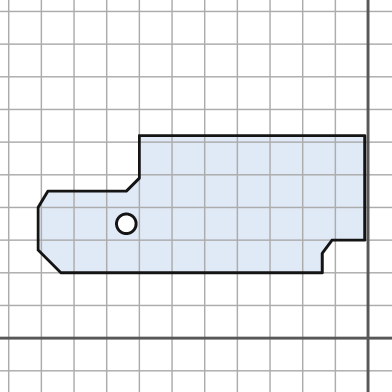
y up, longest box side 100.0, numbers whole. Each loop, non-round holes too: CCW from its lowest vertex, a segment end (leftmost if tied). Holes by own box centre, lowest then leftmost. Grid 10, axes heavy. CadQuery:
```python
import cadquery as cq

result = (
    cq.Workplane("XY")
    .moveTo(-94.0, 20.0)
    .lineTo(-14.0, 20.0)
    .lineTo(-14.0, 26.0)
    .lineTo(-11.0, 30.0)
    .lineTo(-1.0, 30.0)
    .lineTo(-1.0, 62.0)
    .lineTo(-70.0, 62.0)
    .lineTo(-70.0, 49.0)
    .lineTo(-74.0, 45.0)
    .lineTo(-98.0, 45.0)
    .lineTo(-101.0, 40.0)
    .lineTo(-101.0, 27.0)
    .close()
    .moveTo(-74.0, 35.0)
    .circle(3.0)
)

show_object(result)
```